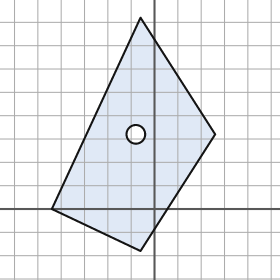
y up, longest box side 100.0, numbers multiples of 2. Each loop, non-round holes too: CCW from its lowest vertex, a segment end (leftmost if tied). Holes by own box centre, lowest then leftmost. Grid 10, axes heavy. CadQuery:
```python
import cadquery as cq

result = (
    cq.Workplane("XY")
    .moveTo(-6.0, -18.0)
    .lineTo(26.0, 32.0)
    .lineTo(-6.0, 82.0)
    .lineTo(-44.0, 0.0)
    .close()
    .moveTo(-8.0, 32.0)
    .circle(4.0)
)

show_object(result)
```